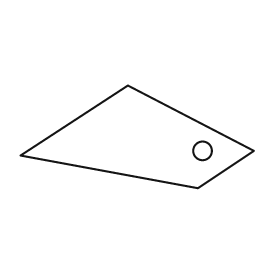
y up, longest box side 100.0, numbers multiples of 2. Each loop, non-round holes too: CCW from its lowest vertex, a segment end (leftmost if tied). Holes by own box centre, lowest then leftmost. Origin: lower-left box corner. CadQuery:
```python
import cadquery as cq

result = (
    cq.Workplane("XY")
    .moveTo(76.0, 0.0)
    .lineTo(100.0, 16.0)
    .lineTo(46.0, 44.0)
    .lineTo(0.0, 14.0)
    .close()
    .moveTo(78.0, 16.0)
    .circle(4.0)
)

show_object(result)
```